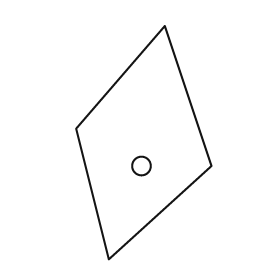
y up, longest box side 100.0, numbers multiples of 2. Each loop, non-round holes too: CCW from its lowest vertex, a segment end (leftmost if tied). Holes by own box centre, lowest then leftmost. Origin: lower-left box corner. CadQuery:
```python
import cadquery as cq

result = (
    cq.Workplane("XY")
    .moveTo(14.0, 0.0)
    .lineTo(58.0, 40.0)
    .lineTo(38.0, 100.0)
    .lineTo(0.0, 56.0)
    .close()
    .moveTo(28.0, 40.0)
    .circle(4.0)
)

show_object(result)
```